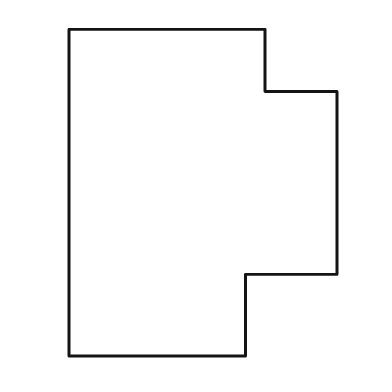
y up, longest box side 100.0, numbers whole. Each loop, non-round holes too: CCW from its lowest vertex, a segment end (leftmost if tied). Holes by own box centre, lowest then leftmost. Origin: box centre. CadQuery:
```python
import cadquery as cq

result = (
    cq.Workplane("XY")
    .moveTo(-41.0, -50.0)
    .lineTo(13.0, -50.0)
    .lineTo(13.0, -25.0)
    .lineTo(41.0, -25.0)
    .lineTo(41.0, 31.0)
    .lineTo(19.0, 31.0)
    .lineTo(19.0, 50.0)
    .lineTo(-41.0, 50.0)
    .close()
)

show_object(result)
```